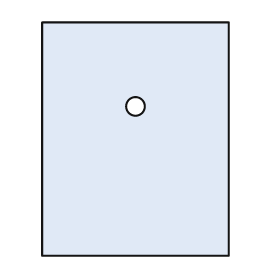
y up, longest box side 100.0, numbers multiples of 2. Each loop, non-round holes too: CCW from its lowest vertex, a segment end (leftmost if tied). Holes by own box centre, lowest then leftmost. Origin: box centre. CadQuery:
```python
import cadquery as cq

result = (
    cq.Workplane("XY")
    .moveTo(-40.0, -50.0)
    .lineTo(40.0, -50.0)
    .lineTo(40.0, 50.0)
    .lineTo(-40.0, 50.0)
    .close()
    .moveTo(0.0, 14.0)
    .circle(4.0)
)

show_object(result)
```